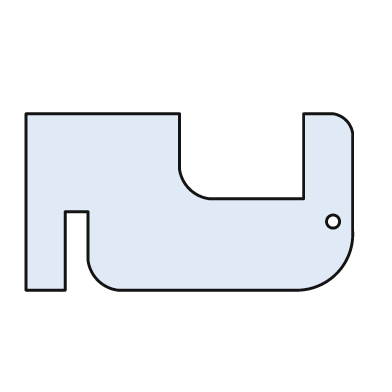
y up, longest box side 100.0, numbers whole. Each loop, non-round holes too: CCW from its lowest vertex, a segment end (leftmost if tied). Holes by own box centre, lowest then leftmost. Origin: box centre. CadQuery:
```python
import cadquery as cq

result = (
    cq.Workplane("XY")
    .moveTo(-50.0, -27.0)
    .lineTo(-38.0, -27.0)
    .lineTo(-38.0, -3.0)
    .lineTo(-31.0, -3.0)
    .lineTo(-31.0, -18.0)
    .threePointArc((-28.0, -24.0), (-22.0, -27.0))
    .lineTo(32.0, -27.0)
    .threePointArc((45.0, -22.0), (50.0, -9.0))
    .lineTo(50.0, 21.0)
    .threePointArc((48.0, 25.0), (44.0, 27.0))
    .lineTo(35.0, 27.0)
    .lineTo(35.0, 1.0)
    .lineTo(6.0, 1.0)
    .threePointArc((0.0, 4.0), (-3.0, 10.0))
    .lineTo(-3.0, 27.0)
    .lineTo(-50.0, 27.0)
    .close()
    .moveTo(44.0, -6.0)
    .circle(2.0)
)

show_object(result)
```